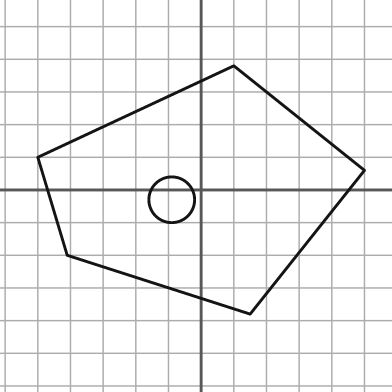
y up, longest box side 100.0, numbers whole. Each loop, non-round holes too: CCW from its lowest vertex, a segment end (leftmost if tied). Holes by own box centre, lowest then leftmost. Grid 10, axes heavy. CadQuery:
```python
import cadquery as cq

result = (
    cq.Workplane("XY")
    .moveTo(15.0, -38.0)
    .lineTo(50.0, 6.0)
    .lineTo(10.0, 38.0)
    .lineTo(-50.0, 10.0)
    .lineTo(-41.0, -20.0)
    .close()
    .moveTo(-9.0, -3.0)
    .circle(7.0)
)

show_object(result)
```